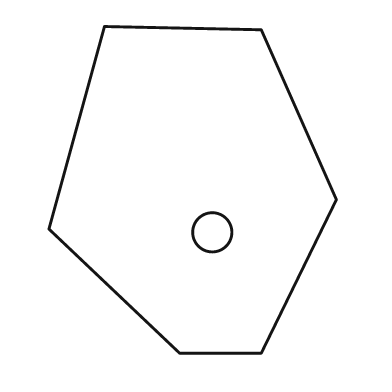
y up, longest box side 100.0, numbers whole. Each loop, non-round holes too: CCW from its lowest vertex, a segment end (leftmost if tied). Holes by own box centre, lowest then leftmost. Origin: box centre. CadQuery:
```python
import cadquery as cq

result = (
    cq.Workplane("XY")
    .moveTo(-4.0, -50.0)
    .lineTo(21.0, -50.0)
    .lineTo(44.0, -3.0)
    .lineTo(21.0, 49.0)
    .lineTo(-27.0, 50.0)
    .lineTo(-44.0, -12.0)
    .close()
    .moveTo(6.0, -13.0)
    .circle(6.0)
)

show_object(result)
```